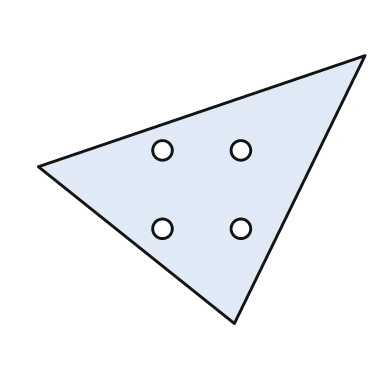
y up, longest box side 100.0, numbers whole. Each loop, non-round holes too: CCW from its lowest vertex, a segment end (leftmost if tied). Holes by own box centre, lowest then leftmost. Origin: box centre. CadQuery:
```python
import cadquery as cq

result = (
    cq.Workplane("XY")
    .moveTo(10.0, -41.0)
    .lineTo(50.0, 41.0)
    .lineTo(-50.0, 7.0)
    .close()
    .moveTo(-12.0, -12.0)
    .circle(3.0)
    .moveTo(12.0, -12.0)
    .circle(3.0)
    .moveTo(-12.0, 12.0)
    .circle(3.0)
    .moveTo(12.0, 12.0)
    .circle(3.0)
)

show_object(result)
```